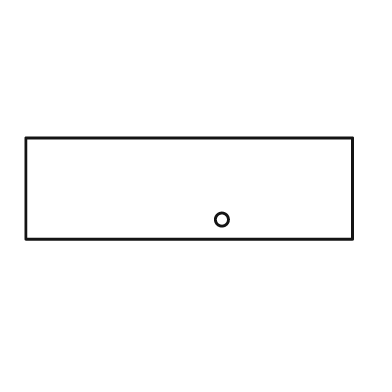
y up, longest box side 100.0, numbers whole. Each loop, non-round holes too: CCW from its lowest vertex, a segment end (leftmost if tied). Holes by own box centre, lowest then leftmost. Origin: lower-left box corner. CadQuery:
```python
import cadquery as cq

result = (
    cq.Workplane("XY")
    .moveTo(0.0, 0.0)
    .lineTo(100.0, 0.0)
    .lineTo(100.0, 31.0)
    .lineTo(0.0, 31.0)
    .close()
    .moveTo(60.0, 6.0)
    .circle(2.0)
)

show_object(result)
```